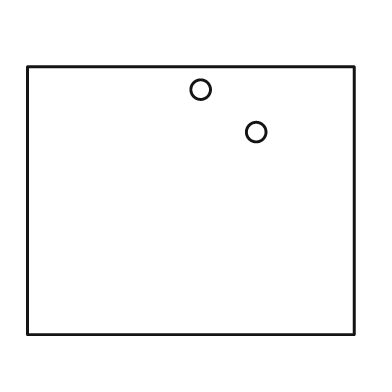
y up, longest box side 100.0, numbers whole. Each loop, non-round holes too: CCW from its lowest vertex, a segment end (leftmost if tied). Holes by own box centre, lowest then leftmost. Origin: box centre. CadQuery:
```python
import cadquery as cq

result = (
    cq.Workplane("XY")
    .moveTo(-50.0, -41.0)
    .lineTo(50.0, -41.0)
    .lineTo(50.0, 41.0)
    .lineTo(-50.0, 41.0)
    .close()
    .moveTo(20.0, 21.0)
    .circle(3.0)
    .moveTo(3.0, 34.0)
    .circle(3.0)
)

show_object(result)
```